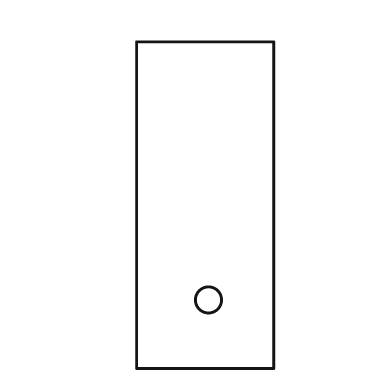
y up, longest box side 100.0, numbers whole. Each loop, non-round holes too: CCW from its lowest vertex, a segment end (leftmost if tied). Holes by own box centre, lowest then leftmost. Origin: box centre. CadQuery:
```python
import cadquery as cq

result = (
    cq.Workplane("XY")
    .moveTo(-21.0, -50.0)
    .lineTo(21.0, -50.0)
    .lineTo(21.0, 50.0)
    .lineTo(-21.0, 50.0)
    .close()
    .moveTo(1.0, -29.0)
    .circle(4.0)
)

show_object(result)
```